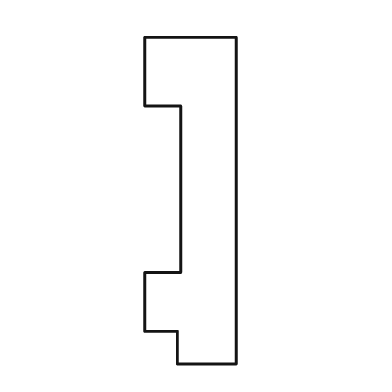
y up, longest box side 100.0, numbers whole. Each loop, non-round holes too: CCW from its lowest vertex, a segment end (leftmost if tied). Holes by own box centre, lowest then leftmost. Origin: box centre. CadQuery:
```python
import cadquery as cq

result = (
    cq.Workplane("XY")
    .moveTo(-4.0, -50.0)
    .lineTo(14.0, -50.0)
    .lineTo(14.0, 50.0)
    .lineTo(-14.0, 50.0)
    .lineTo(-14.0, 29.0)
    .lineTo(-3.0, 29.0)
    .lineTo(-3.0, -22.0)
    .lineTo(-14.0, -22.0)
    .lineTo(-14.0, -40.0)
    .lineTo(-4.0, -40.0)
    .close()
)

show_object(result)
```